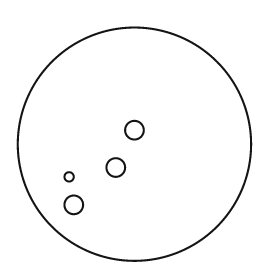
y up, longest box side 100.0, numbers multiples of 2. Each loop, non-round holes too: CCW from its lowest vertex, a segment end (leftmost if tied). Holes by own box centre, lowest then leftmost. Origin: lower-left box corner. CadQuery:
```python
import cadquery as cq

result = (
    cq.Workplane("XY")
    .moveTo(50.0, 50.0)
    .circle(50.0)
    .moveTo(24.0, 24.0)
    .circle(4.0)
    .moveTo(22.0, 36.0)
    .circle(2.0)
    .moveTo(42.0, 40.0)
    .circle(4.0)
    .moveTo(50.0, 56.0)
    .circle(4.0)
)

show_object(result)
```